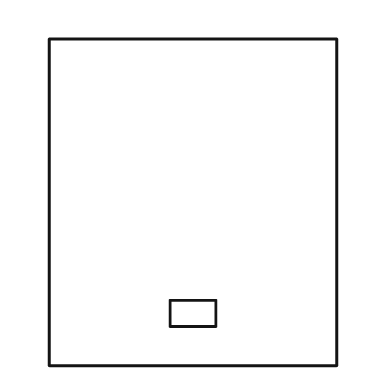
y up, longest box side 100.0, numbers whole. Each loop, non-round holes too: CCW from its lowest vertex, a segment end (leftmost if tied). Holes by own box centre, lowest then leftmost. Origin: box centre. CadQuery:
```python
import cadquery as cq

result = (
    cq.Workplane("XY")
    .moveTo(-44.0, -50.0)
    .lineTo(44.0, -50.0)
    .lineTo(44.0, 50.0)
    .lineTo(-44.0, 50.0)
    .close()
    .moveTo(-7.0, -38.0)
    .lineTo(7.0, -38.0)
    .lineTo(7.0, -30.0)
    .lineTo(-7.0, -30.0)
    .close()
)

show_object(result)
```